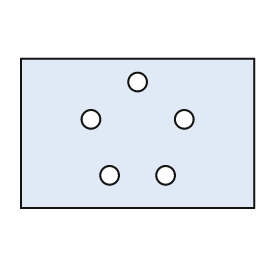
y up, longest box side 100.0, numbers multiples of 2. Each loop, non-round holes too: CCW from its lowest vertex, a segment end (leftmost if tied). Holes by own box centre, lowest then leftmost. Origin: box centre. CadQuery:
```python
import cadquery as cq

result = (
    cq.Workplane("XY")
    .moveTo(-50.0, -32.0)
    .lineTo(50.0, -32.0)
    .lineTo(50.0, 32.0)
    .lineTo(-50.0, 32.0)
    .close()
    .moveTo(-12.0, -18.0)
    .circle(4.0)
    .moveTo(12.0, -18.0)
    .circle(4.0)
    .moveTo(-20.0, 6.0)
    .circle(4.0)
    .moveTo(20.0, 6.0)
    .circle(4.0)
    .moveTo(0.0, 22.0)
    .circle(4.0)
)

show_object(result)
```